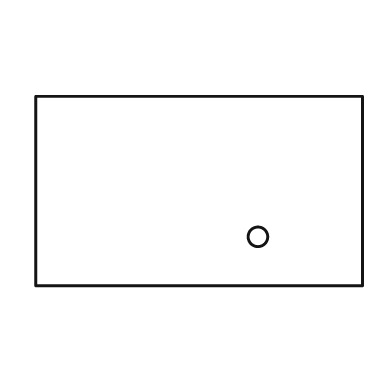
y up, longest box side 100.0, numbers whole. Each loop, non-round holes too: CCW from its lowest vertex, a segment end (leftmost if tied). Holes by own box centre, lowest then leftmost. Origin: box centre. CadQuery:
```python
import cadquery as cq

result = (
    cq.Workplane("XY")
    .moveTo(-50.0, -29.0)
    .lineTo(50.0, -29.0)
    .lineTo(50.0, 29.0)
    .lineTo(-50.0, 29.0)
    .close()
    .moveTo(18.0, -14.0)
    .circle(3.0)
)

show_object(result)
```